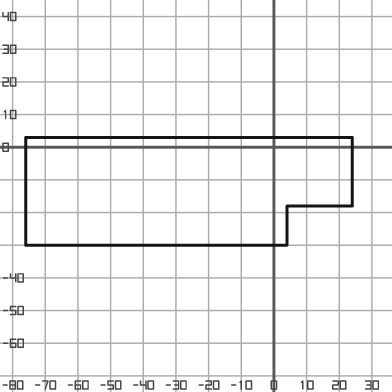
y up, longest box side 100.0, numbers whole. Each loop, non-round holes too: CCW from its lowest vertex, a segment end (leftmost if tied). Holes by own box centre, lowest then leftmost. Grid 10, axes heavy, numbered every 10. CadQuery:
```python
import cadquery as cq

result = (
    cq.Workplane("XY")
    .moveTo(-76.0, -30.0)
    .lineTo(4.0, -30.0)
    .lineTo(4.0, -18.0)
    .lineTo(24.0, -18.0)
    .lineTo(24.0, 3.0)
    .lineTo(-76.0, 3.0)
    .close()
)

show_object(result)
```